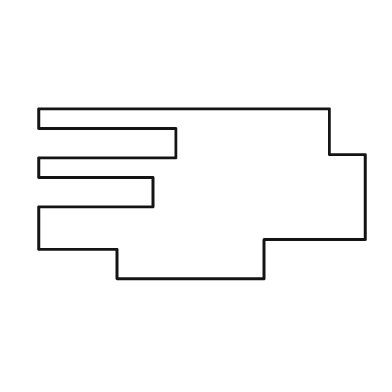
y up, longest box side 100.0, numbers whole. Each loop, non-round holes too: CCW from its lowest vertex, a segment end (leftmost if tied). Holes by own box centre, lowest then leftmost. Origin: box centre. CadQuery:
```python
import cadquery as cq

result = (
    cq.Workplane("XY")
    .moveTo(-26.0, -26.0)
    .lineTo(19.0, -26.0)
    .lineTo(19.0, -14.0)
    .lineTo(50.0, -14.0)
    .lineTo(50.0, 12.0)
    .lineTo(39.0, 12.0)
    .lineTo(39.0, 26.0)
    .lineTo(-50.0, 26.0)
    .lineTo(-50.0, 20.0)
    .lineTo(-8.0, 20.0)
    .lineTo(-8.0, 11.0)
    .lineTo(-50.0, 11.0)
    .lineTo(-50.0, 5.0)
    .lineTo(-15.0, 5.0)
    .lineTo(-15.0, -4.0)
    .lineTo(-50.0, -4.0)
    .lineTo(-50.0, -17.0)
    .lineTo(-26.0, -17.0)
    .close()
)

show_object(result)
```